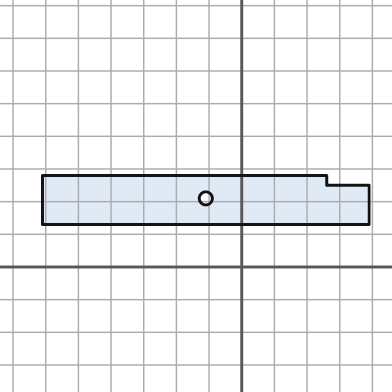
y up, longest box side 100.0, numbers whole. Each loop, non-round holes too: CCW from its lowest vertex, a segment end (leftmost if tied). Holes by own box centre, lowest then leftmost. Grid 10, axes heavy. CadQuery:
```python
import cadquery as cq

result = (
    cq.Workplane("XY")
    .moveTo(-61.0, 13.0)
    .lineTo(39.0, 13.0)
    .lineTo(39.0, 25.0)
    .lineTo(26.0, 25.0)
    .lineTo(26.0, 28.0)
    .lineTo(-61.0, 28.0)
    .close()
    .moveTo(-11.0, 21.0)
    .circle(2.0)
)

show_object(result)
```